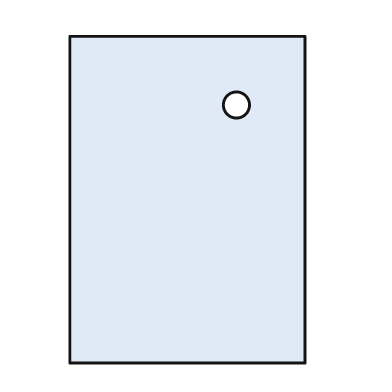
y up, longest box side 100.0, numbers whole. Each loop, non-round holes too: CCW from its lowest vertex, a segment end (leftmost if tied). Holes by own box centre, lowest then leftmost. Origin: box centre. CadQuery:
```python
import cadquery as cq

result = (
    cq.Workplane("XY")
    .moveTo(-36.0, -50.0)
    .lineTo(36.0, -50.0)
    .lineTo(36.0, 50.0)
    .lineTo(-36.0, 50.0)
    .close()
    .moveTo(15.0, 29.0)
    .circle(4.0)
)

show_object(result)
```